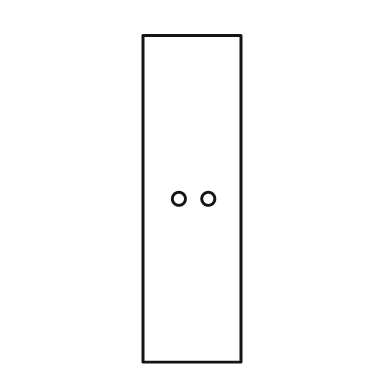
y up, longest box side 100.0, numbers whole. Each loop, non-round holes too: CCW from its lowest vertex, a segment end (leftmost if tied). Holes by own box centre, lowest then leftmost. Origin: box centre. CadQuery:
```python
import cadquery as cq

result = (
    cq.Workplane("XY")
    .moveTo(-15.0, -50.0)
    .lineTo(15.0, -50.0)
    .lineTo(15.0, 50.0)
    .lineTo(-15.0, 50.0)
    .close()
    .moveTo(-4.0, 0.0)
    .circle(2.0)
    .moveTo(5.0, 0.0)
    .circle(2.0)
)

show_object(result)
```